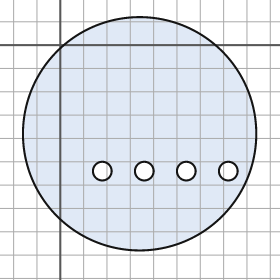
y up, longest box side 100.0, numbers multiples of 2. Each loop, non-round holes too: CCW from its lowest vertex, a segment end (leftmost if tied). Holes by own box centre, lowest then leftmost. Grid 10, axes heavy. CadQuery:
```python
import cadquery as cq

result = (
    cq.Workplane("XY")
    .moveTo(34.0, -38.0)
    .circle(50.0)
    .moveTo(18.0, -54.0)
    .circle(4.0)
    .moveTo(36.0, -54.0)
    .circle(4.0)
    .moveTo(54.0, -54.0)
    .circle(4.0)
    .moveTo(72.0, -54.0)
    .circle(4.0)
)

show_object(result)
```